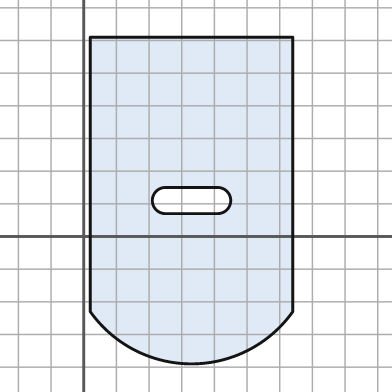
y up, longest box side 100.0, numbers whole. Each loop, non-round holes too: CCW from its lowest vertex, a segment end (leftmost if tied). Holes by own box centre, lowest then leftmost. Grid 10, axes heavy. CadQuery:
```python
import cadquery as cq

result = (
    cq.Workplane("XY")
    .moveTo(2.0, -23.0)
    .threePointArc((33.0, -39.0), (64.0, -23.0))
    .lineTo(64.0, 61.0)
    .lineTo(2.0, 61.0)
    .close()
    .moveTo(25.0, 7.0)
    .lineTo(41.0, 7.0)
    .threePointArc((45.0, 11.0), (41.0, 15.0))
    .lineTo(25.0, 15.0)
    .threePointArc((21.0, 11.0), (25.0, 7.0))
    .close()
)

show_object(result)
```